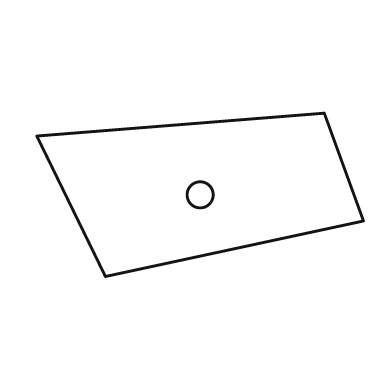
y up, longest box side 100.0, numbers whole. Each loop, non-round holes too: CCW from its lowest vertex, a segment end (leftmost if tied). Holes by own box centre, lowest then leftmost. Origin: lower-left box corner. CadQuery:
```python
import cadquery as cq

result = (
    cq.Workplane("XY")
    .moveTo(21.0, 0.0)
    .lineTo(100.0, 17.0)
    .lineTo(88.0, 50.0)
    .lineTo(0.0, 43.0)
    .close()
    .moveTo(50.0, 25.0)
    .circle(4.0)
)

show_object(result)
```